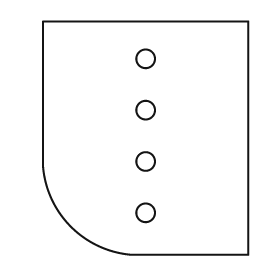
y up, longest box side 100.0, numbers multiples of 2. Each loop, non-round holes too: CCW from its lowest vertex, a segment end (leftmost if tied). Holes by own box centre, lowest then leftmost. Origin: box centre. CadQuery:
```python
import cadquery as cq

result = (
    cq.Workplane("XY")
    .moveTo(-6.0, -50.0)
    .lineTo(44.0, -50.0)
    .lineTo(44.0, 50.0)
    .lineTo(-44.0, 50.0)
    .lineTo(-44.0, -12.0)
    .threePointArc((-32.0, -38.0), (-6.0, -50.0))
    .close()
    .moveTo(0.0, -32.0)
    .circle(4.0)
    .moveTo(0.0, -10.0)
    .circle(4.0)
    .moveTo(0.0, 12.0)
    .circle(4.0)
    .moveTo(0.0, 34.0)
    .circle(4.0)
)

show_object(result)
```